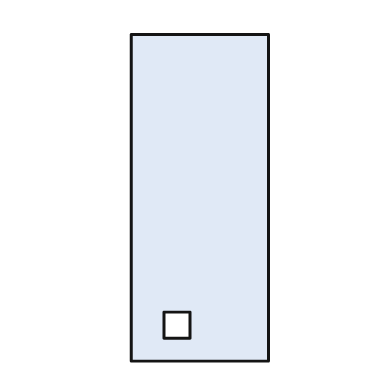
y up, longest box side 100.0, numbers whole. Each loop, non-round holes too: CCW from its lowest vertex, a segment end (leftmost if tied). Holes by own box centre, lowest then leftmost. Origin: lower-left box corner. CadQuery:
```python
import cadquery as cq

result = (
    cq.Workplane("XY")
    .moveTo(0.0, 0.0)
    .lineTo(42.0, 0.0)
    .lineTo(42.0, 100.0)
    .lineTo(0.0, 100.0)
    .close()
    .moveTo(10.0, 7.0)
    .lineTo(18.0, 7.0)
    .lineTo(18.0, 15.0)
    .lineTo(10.0, 15.0)
    .close()
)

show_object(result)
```